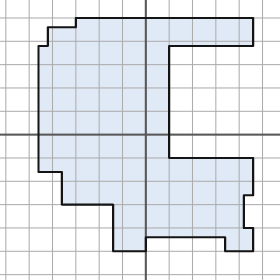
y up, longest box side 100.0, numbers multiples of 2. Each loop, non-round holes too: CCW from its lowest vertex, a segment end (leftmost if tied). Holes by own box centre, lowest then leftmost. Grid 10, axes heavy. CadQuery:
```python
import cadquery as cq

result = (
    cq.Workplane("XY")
    .moveTo(-14.0, -50.0)
    .lineTo(0.0, -50.0)
    .lineTo(0.0, -44.0)
    .lineTo(34.0, -44.0)
    .lineTo(34.0, -50.0)
    .lineTo(46.0, -50.0)
    .lineTo(46.0, -40.0)
    .lineTo(42.0, -40.0)
    .lineTo(42.0, -26.0)
    .lineTo(46.0, -26.0)
    .lineTo(46.0, -10.0)
    .lineTo(10.0, -10.0)
    .lineTo(10.0, 38.0)
    .lineTo(46.0, 38.0)
    .lineTo(46.0, 50.0)
    .lineTo(-30.0, 50.0)
    .lineTo(-30.0, 46.0)
    .lineTo(-42.0, 46.0)
    .lineTo(-42.0, 38.0)
    .lineTo(-46.0, 38.0)
    .lineTo(-46.0, -16.0)
    .lineTo(-36.0, -16.0)
    .lineTo(-36.0, -30.0)
    .lineTo(-14.0, -30.0)
    .close()
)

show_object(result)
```